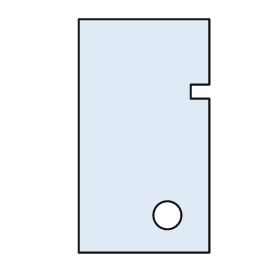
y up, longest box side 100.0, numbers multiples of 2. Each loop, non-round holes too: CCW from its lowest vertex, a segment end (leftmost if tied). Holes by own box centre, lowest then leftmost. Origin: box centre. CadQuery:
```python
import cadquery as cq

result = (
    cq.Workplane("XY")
    .moveTo(-28.0, -50.0)
    .lineTo(28.0, -50.0)
    .lineTo(28.0, 16.0)
    .lineTo(20.0, 16.0)
    .lineTo(20.0, 22.0)
    .lineTo(28.0, 22.0)
    .lineTo(28.0, 50.0)
    .lineTo(-28.0, 50.0)
    .close()
    .moveTo(10.0, -34.0)
    .circle(6.0)
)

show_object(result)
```